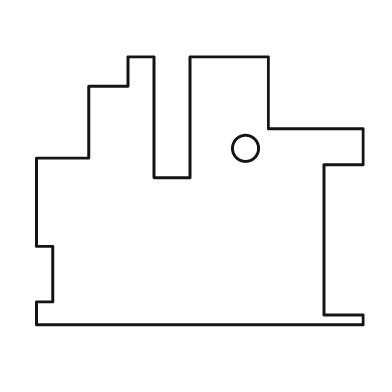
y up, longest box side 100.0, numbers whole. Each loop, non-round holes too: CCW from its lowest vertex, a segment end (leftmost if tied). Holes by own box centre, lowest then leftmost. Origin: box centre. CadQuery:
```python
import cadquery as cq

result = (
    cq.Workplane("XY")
    .moveTo(-50.0, -41.0)
    .lineTo(50.0, -41.0)
    .lineTo(50.0, -38.0)
    .lineTo(38.0, -38.0)
    .lineTo(38.0, 8.0)
    .lineTo(50.0, 8.0)
    .lineTo(50.0, 19.0)
    .lineTo(21.0, 19.0)
    .lineTo(21.0, 41.0)
    .lineTo(-3.0, 41.0)
    .lineTo(-3.0, 4.0)
    .lineTo(-14.0, 4.0)
    .lineTo(-14.0, 41.0)
    .lineTo(-22.0, 41.0)
    .lineTo(-22.0, 32.0)
    .lineTo(-34.0, 32.0)
    .lineTo(-34.0, 10.0)
    .lineTo(-50.0, 10.0)
    .lineTo(-50.0, -17.0)
    .lineTo(-45.0, -17.0)
    .lineTo(-45.0, -34.0)
    .lineTo(-50.0, -34.0)
    .close()
    .moveTo(14.0, 13.0)
    .circle(4.0)
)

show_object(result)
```